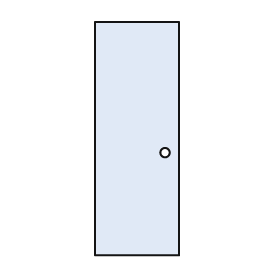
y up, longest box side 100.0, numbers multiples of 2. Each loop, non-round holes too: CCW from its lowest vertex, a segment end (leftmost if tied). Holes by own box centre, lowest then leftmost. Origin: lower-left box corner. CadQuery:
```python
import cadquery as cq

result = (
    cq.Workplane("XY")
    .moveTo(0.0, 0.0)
    .lineTo(36.0, 0.0)
    .lineTo(36.0, 100.0)
    .lineTo(0.0, 100.0)
    .close()
    .moveTo(30.0, 44.0)
    .circle(2.0)
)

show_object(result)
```